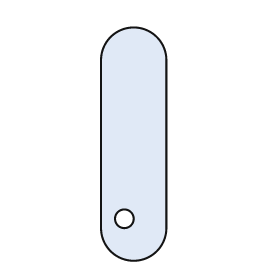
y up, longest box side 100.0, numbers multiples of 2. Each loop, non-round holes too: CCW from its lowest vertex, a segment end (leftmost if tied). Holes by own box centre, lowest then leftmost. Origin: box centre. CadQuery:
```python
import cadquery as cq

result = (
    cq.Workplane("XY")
    .moveTo(-14.0, -36.0)
    .threePointArc((0.0, -50.0), (14.0, -36.0))
    .lineTo(14.0, 36.0)
    .threePointArc((0.0, 50.0), (-14.0, 36.0))
    .close()
    .moveTo(-4.0, -32.0)
    .circle(4.0)
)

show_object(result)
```